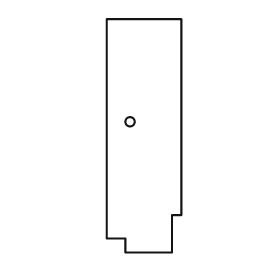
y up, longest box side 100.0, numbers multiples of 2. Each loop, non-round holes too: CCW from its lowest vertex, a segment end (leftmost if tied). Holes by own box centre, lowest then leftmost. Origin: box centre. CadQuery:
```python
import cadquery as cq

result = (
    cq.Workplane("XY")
    .moveTo(-8.0, -50.0)
    .lineTo(12.0, -50.0)
    .lineTo(12.0, -34.0)
    .lineTo(16.0, -34.0)
    .lineTo(16.0, 50.0)
    .lineTo(-16.0, 50.0)
    .lineTo(-16.0, -44.0)
    .lineTo(-8.0, -44.0)
    .close()
    .moveTo(-6.0, 6.0)
    .circle(2.0)
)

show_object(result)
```